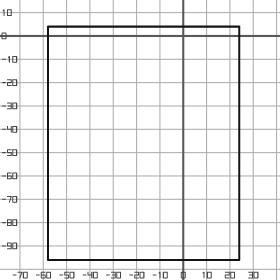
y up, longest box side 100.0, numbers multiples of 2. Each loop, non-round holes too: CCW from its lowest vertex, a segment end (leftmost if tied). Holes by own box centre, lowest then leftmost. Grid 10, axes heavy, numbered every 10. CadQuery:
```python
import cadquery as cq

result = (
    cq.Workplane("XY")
    .moveTo(-58.0, -96.0)
    .lineTo(24.0, -96.0)
    .lineTo(24.0, 4.0)
    .lineTo(-58.0, 4.0)
    .close()
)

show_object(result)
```